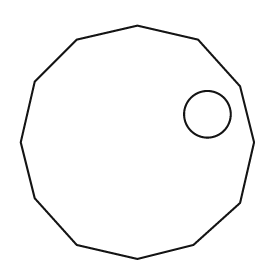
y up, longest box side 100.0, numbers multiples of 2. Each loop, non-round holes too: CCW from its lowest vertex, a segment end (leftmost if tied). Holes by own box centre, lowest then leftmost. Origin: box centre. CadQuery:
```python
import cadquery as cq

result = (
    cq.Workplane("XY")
    .moveTo(0.0, -50.0)
    .lineTo(24.0, -44.0)
    .lineTo(44.0, -26.0)
    .lineTo(50.0, 0.0)
    .lineTo(44.0, 24.0)
    .lineTo(26.0, 44.0)
    .lineTo(0.0, 50.0)
    .lineTo(-26.0, 44.0)
    .lineTo(-44.0, 26.0)
    .lineTo(-50.0, 0.0)
    .lineTo(-44.0, -24.0)
    .lineTo(-26.0, -44.0)
    .close()
    .moveTo(30.0, 12.0)
    .circle(10.0)
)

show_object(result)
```